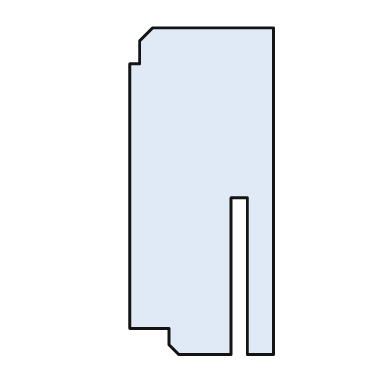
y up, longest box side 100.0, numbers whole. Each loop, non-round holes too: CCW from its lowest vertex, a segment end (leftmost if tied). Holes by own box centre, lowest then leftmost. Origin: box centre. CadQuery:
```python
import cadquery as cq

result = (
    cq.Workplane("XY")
    .moveTo(-7.0, -50.0)
    .lineTo(9.0, -50.0)
    .lineTo(9.0, -2.0)
    .lineTo(14.0, -2.0)
    .lineTo(14.0, -50.0)
    .lineTo(22.0, -50.0)
    .lineTo(22.0, 50.0)
    .lineTo(-15.0, 50.0)
    .lineTo(-19.0, 46.0)
    .lineTo(-19.0, 39.0)
    .lineTo(-22.0, 39.0)
    .lineTo(-22.0, -42.0)
    .lineTo(-10.0, -42.0)
    .lineTo(-10.0, -47.0)
    .close()
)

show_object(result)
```